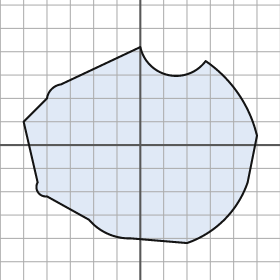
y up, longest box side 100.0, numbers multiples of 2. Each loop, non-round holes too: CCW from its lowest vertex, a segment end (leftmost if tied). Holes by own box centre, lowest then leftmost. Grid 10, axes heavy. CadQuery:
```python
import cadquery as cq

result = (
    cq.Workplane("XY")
    .moveTo(20.0, -42.0)
    .threePointArc((36.0, -32.0), (46.0, -16.0))
    .lineTo(50.0, 4.0)
    .threePointArc((42.0, 22.0), (28.0, 36.0))
    .threePointArc((12.0, 30.0), (0.0, 42.0))
    .lineTo(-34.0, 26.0)
    .threePointArc((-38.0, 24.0), (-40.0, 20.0))
    .lineTo(-50.0, 10.0)
    .lineTo(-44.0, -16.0)
    .threePointArc((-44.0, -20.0), (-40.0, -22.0))
    .lineTo(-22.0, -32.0)
    .threePointArc((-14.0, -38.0), (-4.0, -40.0))
    .close()
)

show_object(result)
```